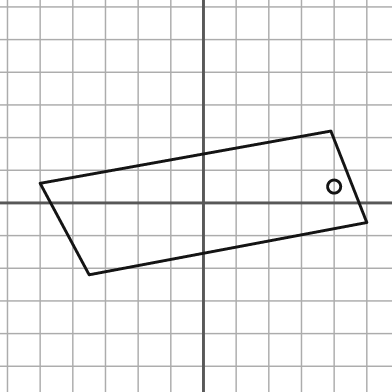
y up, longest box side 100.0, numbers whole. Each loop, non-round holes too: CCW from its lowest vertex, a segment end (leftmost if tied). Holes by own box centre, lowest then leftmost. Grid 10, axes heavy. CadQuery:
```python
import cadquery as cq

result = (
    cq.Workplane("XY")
    .moveTo(-35.0, -22.0)
    .lineTo(50.0, -6.0)
    .lineTo(39.0, 22.0)
    .lineTo(-50.0, 6.0)
    .close()
    .moveTo(40.0, 5.0)
    .circle(2.0)
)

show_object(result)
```